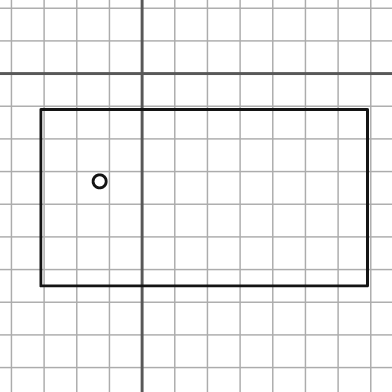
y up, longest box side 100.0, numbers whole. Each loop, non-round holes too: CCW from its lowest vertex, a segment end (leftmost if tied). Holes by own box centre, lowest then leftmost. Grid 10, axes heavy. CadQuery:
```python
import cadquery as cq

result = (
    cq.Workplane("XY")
    .moveTo(-31.0, -65.0)
    .lineTo(69.0, -65.0)
    .lineTo(69.0, -11.0)
    .lineTo(-31.0, -11.0)
    .close()
    .moveTo(-13.0, -33.0)
    .circle(2.0)
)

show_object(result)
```